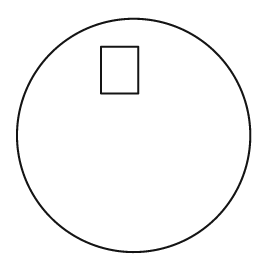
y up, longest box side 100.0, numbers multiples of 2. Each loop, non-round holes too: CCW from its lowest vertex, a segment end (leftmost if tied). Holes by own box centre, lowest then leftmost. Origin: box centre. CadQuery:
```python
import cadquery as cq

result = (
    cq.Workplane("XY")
    .moveTo(0.0, 0.0)
    .circle(50.0)
    .moveTo(-14.0, 18.0)
    .lineTo(2.0, 18.0)
    .lineTo(2.0, 38.0)
    .lineTo(-14.0, 38.0)
    .close()
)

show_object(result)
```